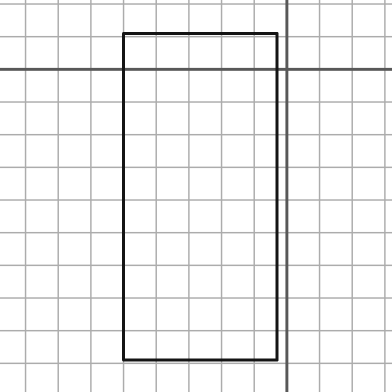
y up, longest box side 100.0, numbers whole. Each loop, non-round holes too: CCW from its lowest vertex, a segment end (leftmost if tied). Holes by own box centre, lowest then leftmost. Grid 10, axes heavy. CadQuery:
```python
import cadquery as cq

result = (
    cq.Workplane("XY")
    .moveTo(-50.0, -89.0)
    .lineTo(-3.0, -89.0)
    .lineTo(-3.0, 11.0)
    .lineTo(-50.0, 11.0)
    .close()
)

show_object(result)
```